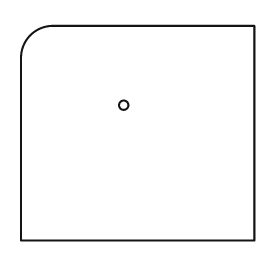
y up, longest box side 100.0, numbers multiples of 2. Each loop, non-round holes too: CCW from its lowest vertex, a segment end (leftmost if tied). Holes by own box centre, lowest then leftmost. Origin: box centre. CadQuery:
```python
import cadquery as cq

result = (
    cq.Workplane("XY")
    .moveTo(-50.0, -46.0)
    .lineTo(50.0, -46.0)
    .lineTo(50.0, 46.0)
    .lineTo(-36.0, 46.0)
    .threePointArc((-46.0, 42.0), (-50.0, 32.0))
    .close()
    .moveTo(-6.0, 12.0)
    .circle(2.0)
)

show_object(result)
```